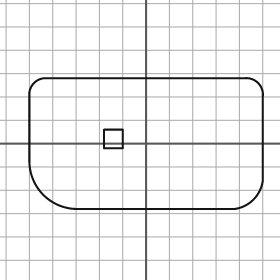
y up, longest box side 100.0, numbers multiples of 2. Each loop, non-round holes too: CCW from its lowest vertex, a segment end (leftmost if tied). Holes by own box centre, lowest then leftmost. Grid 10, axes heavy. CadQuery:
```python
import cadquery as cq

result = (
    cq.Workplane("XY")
    .moveTo(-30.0, -28.0)
    .lineTo(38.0, -28.0)
    .threePointArc((46.0, -24.0), (50.0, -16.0))
    .lineTo(50.0, 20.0)
    .threePointArc((48.0, 26.0), (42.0, 28.0))
    .lineTo(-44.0, 28.0)
    .threePointArc((-48.0, 26.0), (-50.0, 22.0))
    .lineTo(-50.0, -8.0)
    .threePointArc((-44.0, -22.0), (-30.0, -28.0))
    .close()
    .moveTo(-18.0, -2.0)
    .lineTo(-10.0, -2.0)
    .lineTo(-10.0, 6.0)
    .lineTo(-18.0, 6.0)
    .close()
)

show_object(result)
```